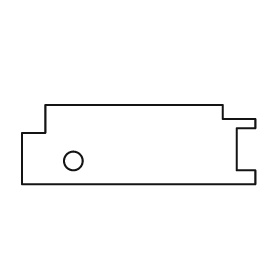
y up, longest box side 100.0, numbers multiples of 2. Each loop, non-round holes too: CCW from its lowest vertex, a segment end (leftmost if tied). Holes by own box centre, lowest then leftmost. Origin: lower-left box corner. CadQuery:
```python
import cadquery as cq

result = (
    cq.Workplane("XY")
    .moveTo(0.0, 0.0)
    .lineTo(100.0, 0.0)
    .lineTo(100.0, 6.0)
    .lineTo(92.0, 6.0)
    .lineTo(92.0, 24.0)
    .lineTo(100.0, 24.0)
    .lineTo(100.0, 28.0)
    .lineTo(86.0, 28.0)
    .lineTo(86.0, 34.0)
    .lineTo(10.0, 34.0)
    .lineTo(10.0, 22.0)
    .lineTo(0.0, 22.0)
    .close()
    .moveTo(22.0, 10.0)
    .circle(4.0)
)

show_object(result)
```